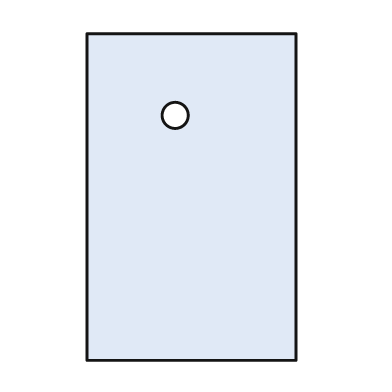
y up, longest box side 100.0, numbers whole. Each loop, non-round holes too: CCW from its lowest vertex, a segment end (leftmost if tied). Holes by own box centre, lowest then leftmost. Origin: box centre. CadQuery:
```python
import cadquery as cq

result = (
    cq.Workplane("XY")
    .moveTo(-32.0, -50.0)
    .lineTo(32.0, -50.0)
    .lineTo(32.0, 50.0)
    .lineTo(-32.0, 50.0)
    .close()
    .moveTo(-5.0, 25.0)
    .circle(4.0)
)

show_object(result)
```